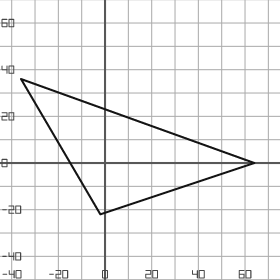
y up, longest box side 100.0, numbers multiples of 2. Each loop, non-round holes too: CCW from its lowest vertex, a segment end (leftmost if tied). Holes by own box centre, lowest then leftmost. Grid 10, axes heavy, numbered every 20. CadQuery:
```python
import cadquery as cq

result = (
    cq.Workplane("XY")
    .moveTo(-2.0, -22.0)
    .lineTo(64.0, 0.0)
    .lineTo(-36.0, 36.0)
    .close()
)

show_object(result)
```